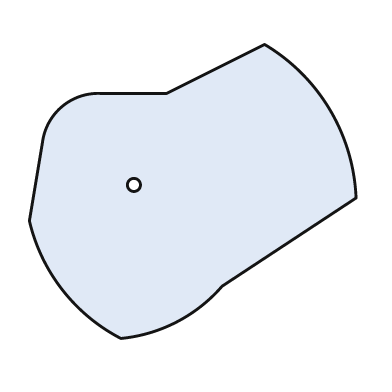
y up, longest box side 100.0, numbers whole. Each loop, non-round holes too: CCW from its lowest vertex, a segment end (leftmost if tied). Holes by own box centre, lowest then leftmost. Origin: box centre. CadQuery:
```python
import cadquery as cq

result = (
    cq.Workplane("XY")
    .moveTo(-22.0, -45.0)
    .threePointArc((-5.0, -40.0), (9.0, -29.0))
    .lineTo(50.0, -2.0)
    .threePointArc((42.0, 25.0), (22.0, 45.0))
    .lineTo(-8.0, 30.0)
    .lineTo(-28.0, 30.0)
    .threePointArc((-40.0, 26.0), (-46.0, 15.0))
    .lineTo(-50.0, -9.0)
    .threePointArc((-40.0, -30.0), (-22.0, -45.0))
    .close()
    .moveTo(-18.0, 2.0)
    .circle(2.0)
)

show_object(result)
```